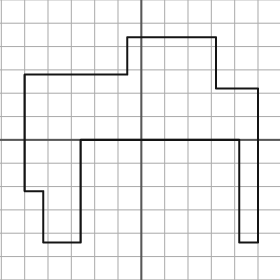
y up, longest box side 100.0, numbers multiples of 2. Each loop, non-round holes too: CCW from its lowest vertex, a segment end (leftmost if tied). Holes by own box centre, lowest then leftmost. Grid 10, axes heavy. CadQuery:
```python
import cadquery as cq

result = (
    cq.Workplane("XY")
    .moveTo(-42.0, -44.0)
    .lineTo(-26.0, -44.0)
    .lineTo(-26.0, 0.0)
    .lineTo(42.0, 0.0)
    .lineTo(42.0, -44.0)
    .lineTo(50.0, -44.0)
    .lineTo(50.0, 22.0)
    .lineTo(32.0, 22.0)
    .lineTo(32.0, 44.0)
    .lineTo(-6.0, 44.0)
    .lineTo(-6.0, 28.0)
    .lineTo(-50.0, 28.0)
    .lineTo(-50.0, -22.0)
    .lineTo(-42.0, -22.0)
    .close()
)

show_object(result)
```